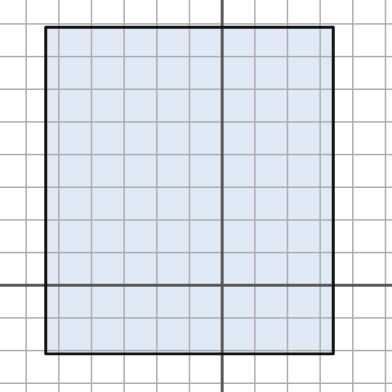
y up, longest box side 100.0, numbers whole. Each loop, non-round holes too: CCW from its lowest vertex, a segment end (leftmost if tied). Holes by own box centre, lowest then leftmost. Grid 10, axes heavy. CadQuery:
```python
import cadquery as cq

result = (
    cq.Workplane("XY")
    .moveTo(-54.0, -21.0)
    .lineTo(34.0, -21.0)
    .lineTo(34.0, 79.0)
    .lineTo(-54.0, 79.0)
    .close()
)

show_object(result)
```